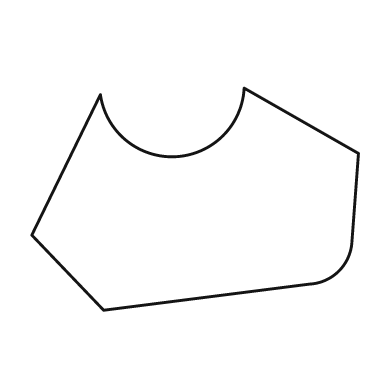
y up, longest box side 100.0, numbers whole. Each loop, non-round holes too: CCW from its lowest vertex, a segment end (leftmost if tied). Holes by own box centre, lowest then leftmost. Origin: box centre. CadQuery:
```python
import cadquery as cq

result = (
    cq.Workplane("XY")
    .moveTo(-28.0, -34.0)
    .lineTo(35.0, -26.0)
    .threePointArc((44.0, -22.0), (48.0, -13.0))
    .lineTo(50.0, 14.0)
    .lineTo(15.0, 34.0)
    .threePointArc((-6.0, 13.0), (-29.0, 32.0))
    .lineTo(-50.0, -11.0)
    .close()
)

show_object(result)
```